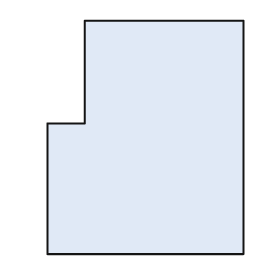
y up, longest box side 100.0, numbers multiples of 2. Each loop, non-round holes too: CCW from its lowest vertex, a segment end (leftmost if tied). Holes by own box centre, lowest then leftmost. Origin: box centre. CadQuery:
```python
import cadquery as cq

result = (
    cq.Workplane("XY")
    .moveTo(-42.0, -50.0)
    .lineTo(42.0, -50.0)
    .lineTo(42.0, 50.0)
    .lineTo(-26.0, 50.0)
    .lineTo(-26.0, 6.0)
    .lineTo(-42.0, 6.0)
    .close()
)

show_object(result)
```